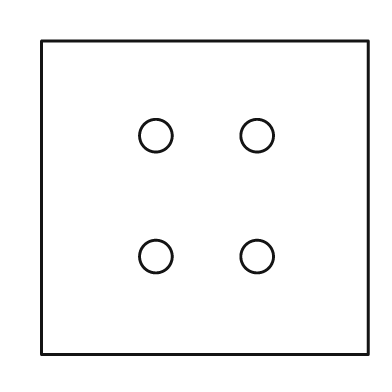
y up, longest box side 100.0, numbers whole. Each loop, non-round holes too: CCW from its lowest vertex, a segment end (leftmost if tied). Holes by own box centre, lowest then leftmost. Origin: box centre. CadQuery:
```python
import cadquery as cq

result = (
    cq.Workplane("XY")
    .moveTo(-50.0, -48.0)
    .lineTo(50.0, -48.0)
    .lineTo(50.0, 48.0)
    .lineTo(-50.0, 48.0)
    .close()
    .moveTo(-15.0, -18.0)
    .circle(5.0)
    .moveTo(16.0, -18.0)
    .circle(5.0)
    .moveTo(-15.0, 19.0)
    .circle(5.0)
    .moveTo(16.0, 19.0)
    .circle(5.0)
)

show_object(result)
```